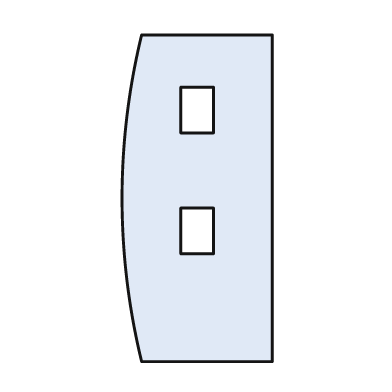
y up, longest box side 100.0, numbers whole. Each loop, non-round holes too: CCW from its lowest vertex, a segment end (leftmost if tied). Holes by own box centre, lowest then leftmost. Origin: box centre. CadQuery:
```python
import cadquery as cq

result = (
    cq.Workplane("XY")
    .moveTo(-17.0, -50.0)
    .lineTo(23.0, -50.0)
    .lineTo(23.0, 50.0)
    .lineTo(-17.0, 50.0)
    .threePointArc((-23.0, 0.0), (-17.0, -50.0))
    .close()
    .moveTo(-5.0, -17.0)
    .lineTo(5.0, -17.0)
    .lineTo(5.0, -3.0)
    .lineTo(-5.0, -3.0)
    .close()
    .moveTo(-5.0, 20.0)
    .lineTo(5.0, 20.0)
    .lineTo(5.0, 34.0)
    .lineTo(-5.0, 34.0)
    .close()
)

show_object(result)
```